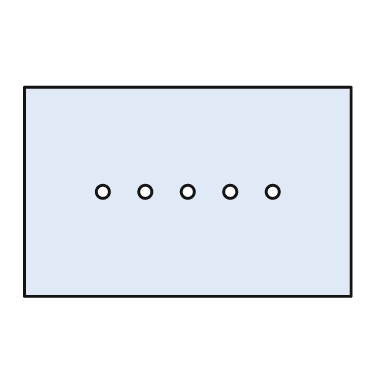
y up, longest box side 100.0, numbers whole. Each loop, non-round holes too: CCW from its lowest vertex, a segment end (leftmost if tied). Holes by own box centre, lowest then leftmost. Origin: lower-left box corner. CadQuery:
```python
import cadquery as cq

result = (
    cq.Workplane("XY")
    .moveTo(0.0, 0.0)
    .lineTo(100.0, 0.0)
    .lineTo(100.0, 64.0)
    .lineTo(0.0, 64.0)
    .close()
    .moveTo(24.0, 32.0)
    .circle(2.0)
    .moveTo(37.0, 32.0)
    .circle(2.0)
    .moveTo(50.0, 32.0)
    .circle(2.0)
    .moveTo(63.0, 32.0)
    .circle(2.0)
    .moveTo(76.0, 32.0)
    .circle(2.0)
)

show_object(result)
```